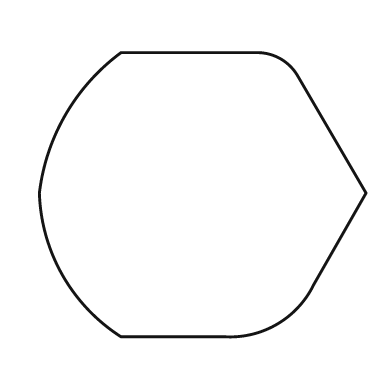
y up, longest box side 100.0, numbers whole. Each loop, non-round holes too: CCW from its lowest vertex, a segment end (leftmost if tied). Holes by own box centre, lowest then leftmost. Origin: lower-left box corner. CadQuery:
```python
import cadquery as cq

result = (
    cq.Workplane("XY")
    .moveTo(25.0, 0.0)
    .lineTo(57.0, 0.0)
    .threePointArc((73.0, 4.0), (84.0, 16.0))
    .lineTo(100.0, 44.0)
    .lineTo(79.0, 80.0)
    .threePointArc((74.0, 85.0), (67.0, 87.0))
    .lineTo(25.0, 87.0)
    .threePointArc((8.0, 68.0), (0.0, 44.0))
    .threePointArc((7.0, 19.0), (25.0, 0.0))
    .close()
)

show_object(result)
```